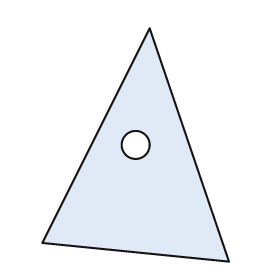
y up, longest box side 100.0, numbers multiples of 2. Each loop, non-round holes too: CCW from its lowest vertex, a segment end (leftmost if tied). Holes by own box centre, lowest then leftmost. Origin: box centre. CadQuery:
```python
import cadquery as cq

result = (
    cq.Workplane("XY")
    .moveTo(40.0, -50.0)
    .lineTo(6.0, 50.0)
    .lineTo(-40.0, -42.0)
    .close()
    .moveTo(0.0, 0.0)
    .circle(6.0)
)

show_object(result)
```